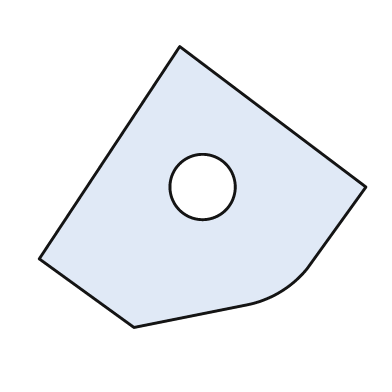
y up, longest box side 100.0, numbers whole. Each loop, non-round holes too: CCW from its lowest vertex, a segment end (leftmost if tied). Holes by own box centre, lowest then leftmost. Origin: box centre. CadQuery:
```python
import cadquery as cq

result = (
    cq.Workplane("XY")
    .moveTo(-21.0, -43.0)
    .lineTo(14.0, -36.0)
    .threePointArc((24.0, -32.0), (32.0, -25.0))
    .lineTo(50.0, 0.0)
    .lineTo(-7.0, 43.0)
    .lineTo(-50.0, -22.0)
    .close()
    .moveTo(0.0, 0.0)
    .circle(10.0)
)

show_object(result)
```